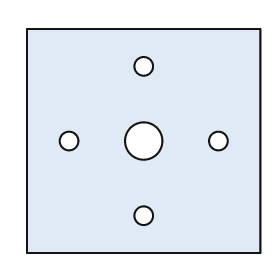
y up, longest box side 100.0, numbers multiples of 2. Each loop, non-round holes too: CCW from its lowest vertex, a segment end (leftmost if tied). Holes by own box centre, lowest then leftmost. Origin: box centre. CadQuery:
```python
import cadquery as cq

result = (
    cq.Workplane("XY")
    .moveTo(-50.0, -48.0)
    .lineTo(50.0, -48.0)
    .lineTo(50.0, 48.0)
    .lineTo(-50.0, 48.0)
    .close()
    .moveTo(0.0, -32.0)
    .circle(4.0)
    .moveTo(-32.0, 0.0)
    .circle(4.0)
    .moveTo(0.0, 0.0)
    .circle(8.0)
    .moveTo(32.0, 0.0)
    .circle(4.0)
    .moveTo(0.0, 32.0)
    .circle(4.0)
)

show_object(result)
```